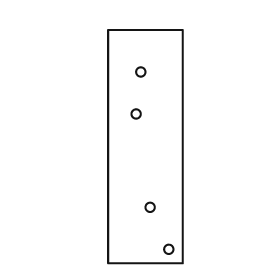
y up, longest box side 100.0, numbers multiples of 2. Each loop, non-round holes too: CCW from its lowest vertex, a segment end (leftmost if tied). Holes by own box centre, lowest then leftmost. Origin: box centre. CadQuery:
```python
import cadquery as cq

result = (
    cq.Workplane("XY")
    .moveTo(-16.0, -50.0)
    .lineTo(16.0, -50.0)
    .lineTo(16.0, 50.0)
    .lineTo(-16.0, 50.0)
    .close()
    .moveTo(10.0, -44.0)
    .circle(2.0)
    .moveTo(2.0, -26.0)
    .circle(2.0)
    .moveTo(-4.0, 14.0)
    .circle(2.0)
    .moveTo(-2.0, 32.0)
    .circle(2.0)
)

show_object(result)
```